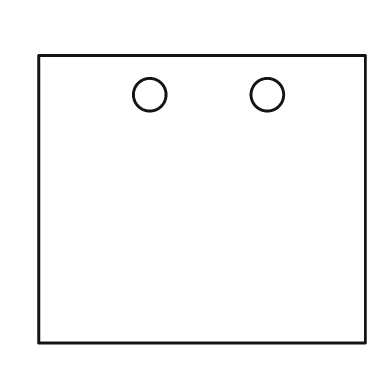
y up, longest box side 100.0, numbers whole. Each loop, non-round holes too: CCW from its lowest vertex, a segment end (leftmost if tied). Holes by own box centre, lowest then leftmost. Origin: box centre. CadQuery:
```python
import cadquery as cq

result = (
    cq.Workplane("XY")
    .moveTo(-50.0, -44.0)
    .lineTo(50.0, -44.0)
    .lineTo(50.0, 44.0)
    .lineTo(-50.0, 44.0)
    .close()
    .moveTo(-16.0, 32.0)
    .circle(5.0)
    .moveTo(20.0, 32.0)
    .circle(5.0)
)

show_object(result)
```